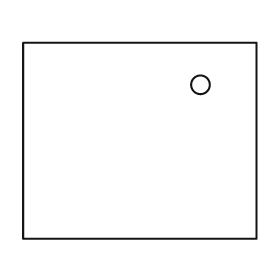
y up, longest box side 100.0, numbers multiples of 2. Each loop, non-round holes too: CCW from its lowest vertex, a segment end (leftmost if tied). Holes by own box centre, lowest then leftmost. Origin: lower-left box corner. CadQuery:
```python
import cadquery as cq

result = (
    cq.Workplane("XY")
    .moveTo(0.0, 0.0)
    .lineTo(100.0, 0.0)
    .lineTo(100.0, 84.0)
    .lineTo(0.0, 84.0)
    .close()
    .moveTo(76.0, 66.0)
    .circle(4.0)
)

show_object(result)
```